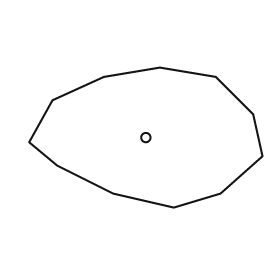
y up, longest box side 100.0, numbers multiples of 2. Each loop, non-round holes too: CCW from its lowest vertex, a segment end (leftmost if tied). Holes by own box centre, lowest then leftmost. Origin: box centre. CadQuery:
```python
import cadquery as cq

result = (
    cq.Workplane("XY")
    .moveTo(12.0, -30.0)
    .lineTo(32.0, -24.0)
    .lineTo(50.0, -8.0)
    .lineTo(46.0, 10.0)
    .lineTo(30.0, 26.0)
    .lineTo(6.0, 30.0)
    .lineTo(-18.0, 26.0)
    .lineTo(-40.0, 16.0)
    .lineTo(-50.0, -2.0)
    .lineTo(-38.0, -12.0)
    .lineTo(-14.0, -24.0)
    .close()
    .moveTo(0.0, 0.0)
    .circle(2.0)
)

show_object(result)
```